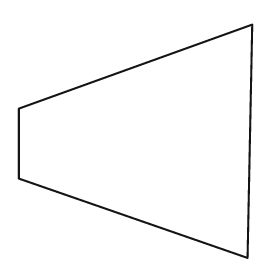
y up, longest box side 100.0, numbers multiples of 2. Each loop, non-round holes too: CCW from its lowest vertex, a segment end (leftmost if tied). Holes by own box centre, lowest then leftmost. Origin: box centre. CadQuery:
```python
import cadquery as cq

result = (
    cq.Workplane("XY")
    .moveTo(48.0, -50.0)
    .lineTo(50.0, 50.0)
    .lineTo(-50.0, 14.0)
    .lineTo(-50.0, -16.0)
    .close()
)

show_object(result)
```